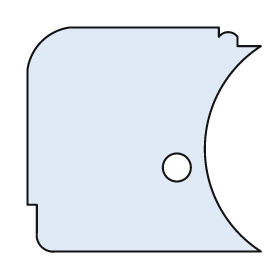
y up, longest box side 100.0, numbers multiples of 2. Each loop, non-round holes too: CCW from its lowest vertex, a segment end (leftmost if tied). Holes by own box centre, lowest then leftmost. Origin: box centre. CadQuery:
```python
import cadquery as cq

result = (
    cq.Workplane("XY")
    .moveTo(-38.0, -48.0)
    .lineTo(50.0, -48.0)
    .threePointArc((26.0, -4.0), (50.0, 40.0))
    .lineTo(40.0, 40.0)
    .lineTo(40.0, 44.0)
    .threePointArc((36.0, 46.0), (32.0, 44.0))
    .lineTo(32.0, 48.0)
    .lineTo(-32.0, 48.0)
    .threePointArc((-44.0, 42.0), (-50.0, 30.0))
    .lineTo(-50.0, -28.0)
    .lineTo(-46.0, -28.0)
    .lineTo(-46.0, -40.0)
    .threePointArc((-44.0, -46.0), (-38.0, -48.0))
    .close()
    .moveTo(14.0, -12.0)
    .circle(6.0)
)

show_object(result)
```